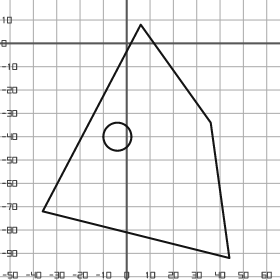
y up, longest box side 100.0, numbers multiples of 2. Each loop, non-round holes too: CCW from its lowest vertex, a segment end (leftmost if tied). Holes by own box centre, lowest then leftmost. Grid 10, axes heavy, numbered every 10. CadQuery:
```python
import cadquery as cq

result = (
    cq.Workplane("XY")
    .moveTo(44.0, -92.0)
    .lineTo(36.0, -34.0)
    .lineTo(6.0, 8.0)
    .lineTo(-36.0, -72.0)
    .close()
    .moveTo(-4.0, -40.0)
    .circle(6.0)
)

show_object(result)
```